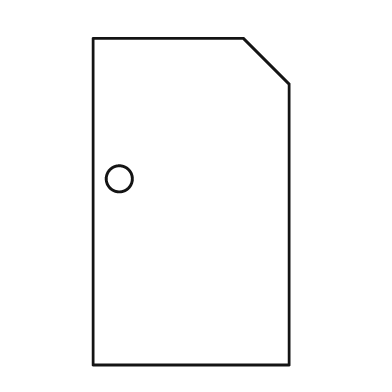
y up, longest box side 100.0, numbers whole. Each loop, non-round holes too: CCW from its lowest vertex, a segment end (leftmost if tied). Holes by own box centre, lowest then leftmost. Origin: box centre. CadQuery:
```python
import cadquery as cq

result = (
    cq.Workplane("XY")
    .moveTo(-30.0, -50.0)
    .lineTo(30.0, -50.0)
    .lineTo(30.0, 36.0)
    .lineTo(16.0, 50.0)
    .lineTo(-30.0, 50.0)
    .close()
    .moveTo(-22.0, 7.0)
    .circle(4.0)
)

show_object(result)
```